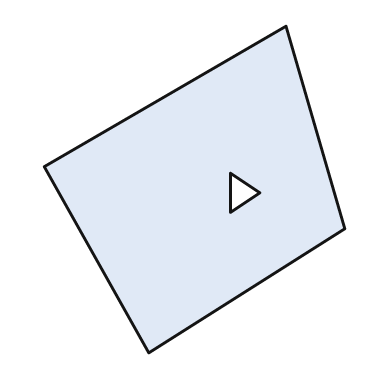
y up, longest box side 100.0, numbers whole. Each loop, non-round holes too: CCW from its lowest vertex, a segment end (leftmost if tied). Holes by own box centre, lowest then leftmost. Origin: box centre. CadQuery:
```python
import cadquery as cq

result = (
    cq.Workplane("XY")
    .moveTo(-14.0, -50.0)
    .lineTo(46.0, -12.0)
    .lineTo(28.0, 50.0)
    .lineTo(-46.0, 7.0)
    .close()
    .moveTo(11.0, -7.0)
    .lineTo(20.0, -1.0)
    .lineTo(11.0, 5.0)
    .close()
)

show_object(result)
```